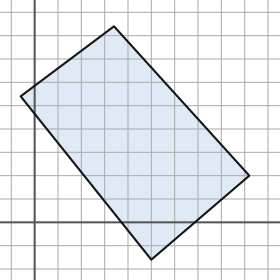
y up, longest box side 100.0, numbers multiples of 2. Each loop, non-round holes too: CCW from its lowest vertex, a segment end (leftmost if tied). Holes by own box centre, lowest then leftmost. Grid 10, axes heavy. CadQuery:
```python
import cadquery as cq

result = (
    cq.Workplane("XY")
    .moveTo(50.0, -16.0)
    .lineTo(92.0, 20.0)
    .lineTo(34.0, 84.0)
    .lineTo(-6.0, 54.0)
    .close()
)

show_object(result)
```